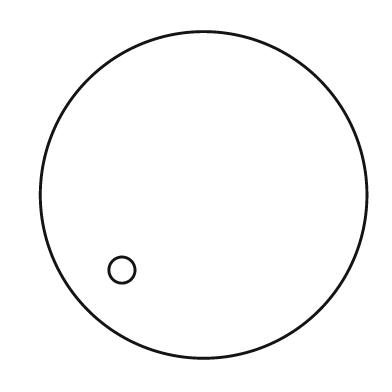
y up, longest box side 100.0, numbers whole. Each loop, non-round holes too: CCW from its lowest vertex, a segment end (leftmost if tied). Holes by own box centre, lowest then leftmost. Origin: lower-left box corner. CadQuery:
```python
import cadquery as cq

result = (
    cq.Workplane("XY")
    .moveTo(50.0, 50.0)
    .circle(50.0)
    .moveTo(25.0, 27.0)
    .circle(4.0)
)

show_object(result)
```